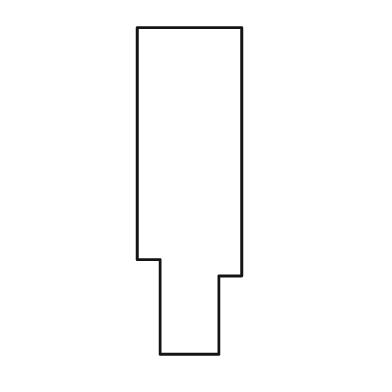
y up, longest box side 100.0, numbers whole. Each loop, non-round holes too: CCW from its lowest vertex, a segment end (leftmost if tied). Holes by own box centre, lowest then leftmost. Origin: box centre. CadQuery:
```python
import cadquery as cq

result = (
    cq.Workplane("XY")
    .moveTo(-9.0, -50.0)
    .lineTo(9.0, -50.0)
    .lineTo(9.0, -26.0)
    .lineTo(16.0, -26.0)
    .lineTo(16.0, 50.0)
    .lineTo(-16.0, 50.0)
    .lineTo(-16.0, -21.0)
    .lineTo(-9.0, -21.0)
    .close()
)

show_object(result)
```